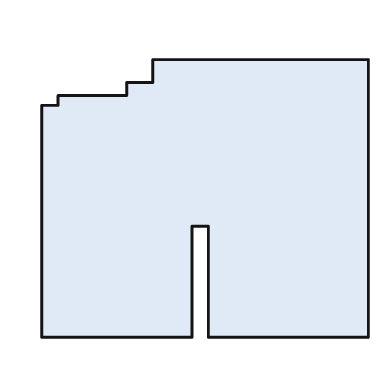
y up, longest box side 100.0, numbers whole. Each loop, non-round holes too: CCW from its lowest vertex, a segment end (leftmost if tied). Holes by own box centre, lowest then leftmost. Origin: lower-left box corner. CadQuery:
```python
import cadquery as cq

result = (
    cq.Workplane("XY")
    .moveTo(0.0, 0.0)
    .lineTo(46.0, 0.0)
    .lineTo(46.0, 34.0)
    .lineTo(51.0, 34.0)
    .lineTo(51.0, 0.0)
    .lineTo(100.0, 0.0)
    .lineTo(100.0, 85.0)
    .lineTo(34.0, 85.0)
    .lineTo(34.0, 78.0)
    .lineTo(26.0, 78.0)
    .lineTo(26.0, 74.0)
    .lineTo(5.0, 74.0)
    .lineTo(5.0, 71.0)
    .lineTo(0.0, 71.0)
    .close()
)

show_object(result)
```